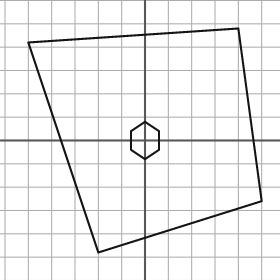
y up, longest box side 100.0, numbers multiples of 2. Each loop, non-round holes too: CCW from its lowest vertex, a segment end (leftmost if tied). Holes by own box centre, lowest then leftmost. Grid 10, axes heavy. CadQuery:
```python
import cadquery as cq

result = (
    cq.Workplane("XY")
    .moveTo(-20.0, -48.0)
    .lineTo(50.0, -26.0)
    .lineTo(40.0, 48.0)
    .lineTo(-50.0, 42.0)
    .close()
    .moveTo(0.0, -8.0)
    .lineTo(6.0, -4.0)
    .lineTo(6.0, 4.0)
    .lineTo(0.0, 8.0)
    .lineTo(-6.0, 4.0)
    .lineTo(-6.0, -4.0)
    .close()
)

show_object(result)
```